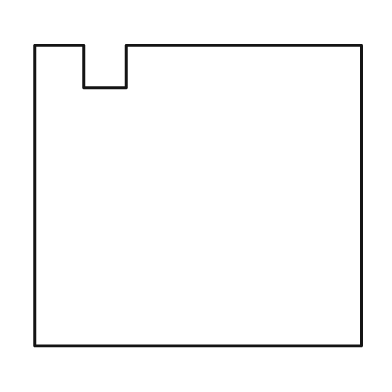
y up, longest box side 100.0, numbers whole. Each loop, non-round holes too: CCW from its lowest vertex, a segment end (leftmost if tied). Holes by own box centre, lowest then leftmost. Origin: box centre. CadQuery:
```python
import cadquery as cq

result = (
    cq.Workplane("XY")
    .moveTo(-50.0, -46.0)
    .lineTo(50.0, -46.0)
    .lineTo(50.0, 46.0)
    .lineTo(-22.0, 46.0)
    .lineTo(-22.0, 33.0)
    .lineTo(-35.0, 33.0)
    .lineTo(-35.0, 46.0)
    .lineTo(-50.0, 46.0)
    .close()
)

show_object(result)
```